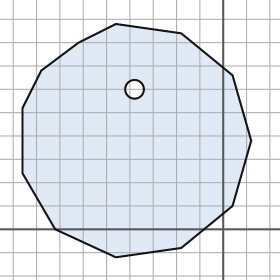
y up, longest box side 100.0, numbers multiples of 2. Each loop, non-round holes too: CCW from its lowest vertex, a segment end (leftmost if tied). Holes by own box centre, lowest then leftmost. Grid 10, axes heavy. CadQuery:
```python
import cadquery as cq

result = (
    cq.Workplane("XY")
    .moveTo(-46.0, -12.0)
    .lineTo(-18.0, -8.0)
    .lineTo(4.0, 10.0)
    .lineTo(12.0, 38.0)
    .lineTo(4.0, 66.0)
    .lineTo(-18.0, 84.0)
    .lineTo(-46.0, 88.0)
    .lineTo(-62.0, 80.0)
    .lineTo(-78.0, 68.0)
    .lineTo(-86.0, 52.0)
    .lineTo(-86.0, 24.0)
    .lineTo(-72.0, 0.0)
    .close()
    .moveTo(-38.0, 60.0)
    .circle(4.0)
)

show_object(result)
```